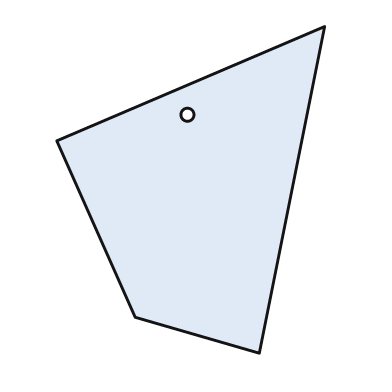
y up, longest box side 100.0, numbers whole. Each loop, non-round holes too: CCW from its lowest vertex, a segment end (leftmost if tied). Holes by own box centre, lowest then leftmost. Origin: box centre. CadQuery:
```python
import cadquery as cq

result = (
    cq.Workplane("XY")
    .moveTo(21.0, -50.0)
    .lineTo(41.0, 50.0)
    .lineTo(-41.0, 15.0)
    .lineTo(-17.0, -39.0)
    .close()
    .moveTo(-1.0, 23.0)
    .circle(2.0)
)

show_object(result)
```